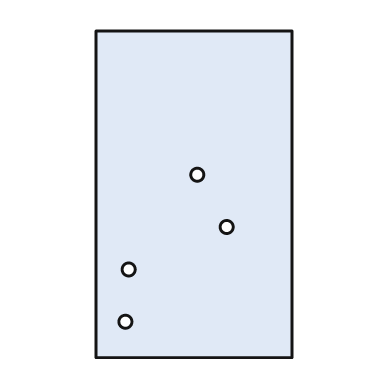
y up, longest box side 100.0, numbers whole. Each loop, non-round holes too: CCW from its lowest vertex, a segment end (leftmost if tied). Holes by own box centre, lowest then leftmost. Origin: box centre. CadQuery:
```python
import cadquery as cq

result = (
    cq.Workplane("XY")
    .moveTo(-30.0, -50.0)
    .lineTo(30.0, -50.0)
    .lineTo(30.0, 50.0)
    .lineTo(-30.0, 50.0)
    .close()
    .moveTo(-21.0, -39.0)
    .circle(2.0)
    .moveTo(-20.0, -23.0)
    .circle(2.0)
    .moveTo(10.0, -10.0)
    .circle(2.0)
    .moveTo(1.0, 6.0)
    .circle(2.0)
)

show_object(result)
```